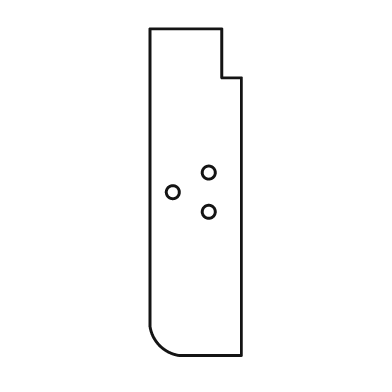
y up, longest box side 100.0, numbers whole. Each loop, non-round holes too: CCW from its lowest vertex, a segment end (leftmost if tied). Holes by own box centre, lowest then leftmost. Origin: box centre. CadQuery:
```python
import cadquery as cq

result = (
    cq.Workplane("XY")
    .moveTo(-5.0, -50.0)
    .lineTo(14.0, -50.0)
    .lineTo(14.0, 35.0)
    .lineTo(8.0, 35.0)
    .lineTo(8.0, 50.0)
    .lineTo(-14.0, 50.0)
    .lineTo(-14.0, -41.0)
    .threePointArc((-11.0, -47.0), (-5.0, -50.0))
    .close()
    .moveTo(4.0, -6.0)
    .circle(2.0)
    .moveTo(-7.0, 0.0)
    .circle(2.0)
    .moveTo(4.0, 6.0)
    .circle(2.0)
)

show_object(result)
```